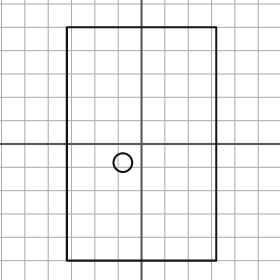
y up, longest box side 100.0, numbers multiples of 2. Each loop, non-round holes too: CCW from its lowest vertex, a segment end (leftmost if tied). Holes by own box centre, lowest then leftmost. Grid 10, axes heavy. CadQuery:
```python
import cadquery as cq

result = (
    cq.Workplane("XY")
    .moveTo(-32.0, -50.0)
    .lineTo(32.0, -50.0)
    .lineTo(32.0, 50.0)
    .lineTo(-32.0, 50.0)
    .close()
    .moveTo(-8.0, -8.0)
    .circle(4.0)
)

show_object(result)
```